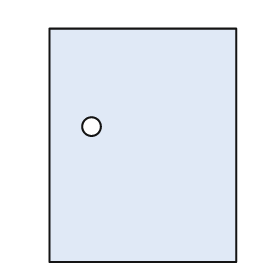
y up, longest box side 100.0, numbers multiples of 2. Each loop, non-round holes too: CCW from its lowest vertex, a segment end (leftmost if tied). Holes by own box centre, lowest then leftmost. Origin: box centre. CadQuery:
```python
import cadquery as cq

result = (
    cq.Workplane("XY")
    .moveTo(-40.0, -50.0)
    .lineTo(40.0, -50.0)
    .lineTo(40.0, 50.0)
    .lineTo(-40.0, 50.0)
    .close()
    .moveTo(-22.0, 8.0)
    .circle(4.0)
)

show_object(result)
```